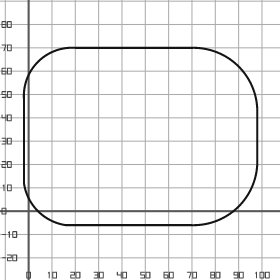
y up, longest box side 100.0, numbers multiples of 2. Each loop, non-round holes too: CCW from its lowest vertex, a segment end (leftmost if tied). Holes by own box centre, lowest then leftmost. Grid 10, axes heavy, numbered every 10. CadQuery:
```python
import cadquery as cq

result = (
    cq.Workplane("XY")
    .moveTo(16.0, -6.0)
    .lineTo(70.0, -6.0)
    .threePointArc((90.0, 2.0), (98.0, 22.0))
    .lineTo(98.0, 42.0)
    .threePointArc((90.0, 62.0), (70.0, 70.0))
    .lineTo(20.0, 70.0)
    .threePointArc((4.0, 64.0), (-2.0, 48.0))
    .lineTo(-2.0, 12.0)
    .threePointArc((4.0, 0.0), (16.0, -6.0))
    .close()
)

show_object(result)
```